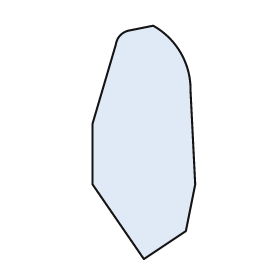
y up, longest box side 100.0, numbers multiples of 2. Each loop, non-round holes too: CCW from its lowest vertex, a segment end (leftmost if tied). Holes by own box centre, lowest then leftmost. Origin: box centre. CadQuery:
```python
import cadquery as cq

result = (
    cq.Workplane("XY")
    .moveTo(0.0, -50.0)
    .lineTo(18.0, -38.0)
    .lineTo(22.0, -18.0)
    .lineTo(20.0, 22.0)
    .threePointArc((16.0, 38.0), (4.0, 50.0))
    .lineTo(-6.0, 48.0)
    .threePointArc((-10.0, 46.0), (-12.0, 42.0))
    .lineTo(-22.0, 8.0)
    .lineTo(-22.0, -18.0)
    .close()
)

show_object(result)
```